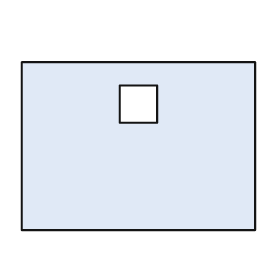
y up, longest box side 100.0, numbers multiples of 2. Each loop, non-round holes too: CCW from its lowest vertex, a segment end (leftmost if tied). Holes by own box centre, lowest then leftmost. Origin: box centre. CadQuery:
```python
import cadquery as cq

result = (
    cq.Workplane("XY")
    .moveTo(-50.0, -36.0)
    .lineTo(50.0, -36.0)
    .lineTo(50.0, 36.0)
    .lineTo(-50.0, 36.0)
    .close()
    .moveTo(-8.0, 10.0)
    .lineTo(8.0, 10.0)
    .lineTo(8.0, 26.0)
    .lineTo(-8.0, 26.0)
    .close()
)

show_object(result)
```